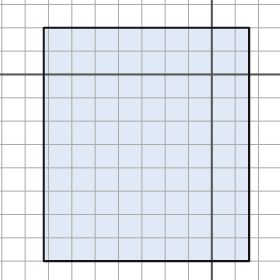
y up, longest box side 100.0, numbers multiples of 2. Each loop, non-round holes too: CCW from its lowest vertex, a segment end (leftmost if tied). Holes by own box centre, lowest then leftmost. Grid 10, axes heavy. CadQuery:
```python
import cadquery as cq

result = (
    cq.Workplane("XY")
    .moveTo(-72.0, -80.0)
    .lineTo(16.0, -80.0)
    .lineTo(16.0, 20.0)
    .lineTo(-72.0, 20.0)
    .close()
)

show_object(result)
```